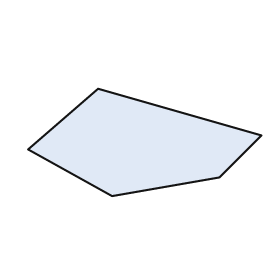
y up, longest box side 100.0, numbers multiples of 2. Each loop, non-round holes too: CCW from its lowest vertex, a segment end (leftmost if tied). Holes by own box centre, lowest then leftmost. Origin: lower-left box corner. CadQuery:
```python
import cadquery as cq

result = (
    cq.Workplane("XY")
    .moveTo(36.0, 0.0)
    .lineTo(82.0, 8.0)
    .lineTo(100.0, 26.0)
    .lineTo(30.0, 46.0)
    .lineTo(0.0, 20.0)
    .close()
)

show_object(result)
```